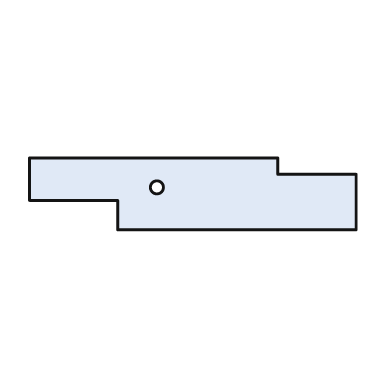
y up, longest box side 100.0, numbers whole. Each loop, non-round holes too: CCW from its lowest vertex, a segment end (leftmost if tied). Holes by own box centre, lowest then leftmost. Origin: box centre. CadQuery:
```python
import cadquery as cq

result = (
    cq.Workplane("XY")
    .moveTo(-23.0, -11.0)
    .lineTo(50.0, -11.0)
    .lineTo(50.0, 6.0)
    .lineTo(26.0, 6.0)
    .lineTo(26.0, 11.0)
    .lineTo(-50.0, 11.0)
    .lineTo(-50.0, -2.0)
    .lineTo(-23.0, -2.0)
    .close()
    .moveTo(-11.0, 2.0)
    .circle(2.0)
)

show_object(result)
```